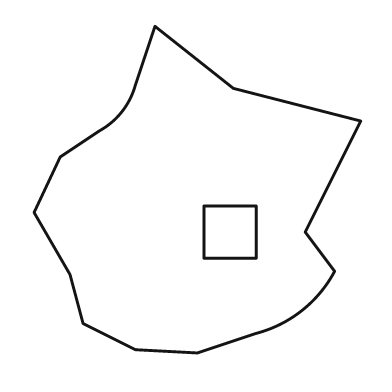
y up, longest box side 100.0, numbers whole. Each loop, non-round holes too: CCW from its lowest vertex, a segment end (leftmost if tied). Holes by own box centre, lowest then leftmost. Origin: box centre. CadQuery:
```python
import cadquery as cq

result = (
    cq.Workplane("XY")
    .moveTo(0.0, -50.0)
    .lineTo(18.0, -44.0)
    .threePointArc((32.0, -37.0), (42.0, -25.0))
    .lineTo(33.0, -13.0)
    .lineTo(50.0, 21.0)
    .lineTo(11.0, 31.0)
    .lineTo(-13.0, 50.0)
    .lineTo(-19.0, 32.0)
    .threePointArc((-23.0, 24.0), (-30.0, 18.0))
    .lineTo(-42.0, 10.0)
    .lineTo(-50.0, -7.0)
    .lineTo(-39.0, -26.0)
    .lineTo(-35.0, -41.0)
    .lineTo(-19.0, -49.0)
    .close()
    .moveTo(2.0, -21.0)
    .lineTo(18.0, -21.0)
    .lineTo(18.0, -5.0)
    .lineTo(2.0, -5.0)
    .close()
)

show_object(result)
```